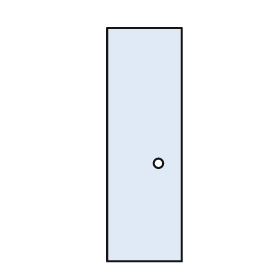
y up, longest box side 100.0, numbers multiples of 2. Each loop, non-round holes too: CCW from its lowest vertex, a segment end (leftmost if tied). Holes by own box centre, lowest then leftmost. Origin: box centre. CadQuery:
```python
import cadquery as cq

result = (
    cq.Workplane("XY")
    .moveTo(-16.0, -50.0)
    .lineTo(16.0, -50.0)
    .lineTo(16.0, 50.0)
    .lineTo(-16.0, 50.0)
    .close()
    .moveTo(6.0, -8.0)
    .circle(2.0)
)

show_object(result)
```